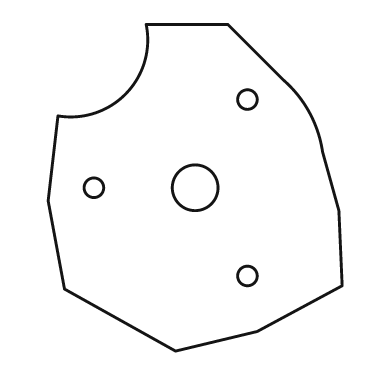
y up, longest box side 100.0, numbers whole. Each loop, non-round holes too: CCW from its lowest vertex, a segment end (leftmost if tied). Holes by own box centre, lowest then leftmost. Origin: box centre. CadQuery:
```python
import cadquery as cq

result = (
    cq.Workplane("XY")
    .moveTo(-6.0, -50.0)
    .lineTo(19.0, -44.0)
    .lineTo(45.0, -30.0)
    .lineTo(44.0, -7.0)
    .lineTo(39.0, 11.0)
    .threePointArc((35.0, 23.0), (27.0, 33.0))
    .lineTo(10.0, 50.0)
    .lineTo(-15.0, 50.0)
    .threePointArc((-21.0, 29.0), (-42.0, 22.0))
    .lineTo(-45.0, -4.0)
    .lineTo(-40.0, -31.0)
    .close()
    .moveTo(16.0, -27.0)
    .circle(3.0)
    .moveTo(-31.0, 0.0)
    .circle(3.0)
    .moveTo(0.0, 0.0)
    .circle(7.0)
    .moveTo(16.0, 27.0)
    .circle(3.0)
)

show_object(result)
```